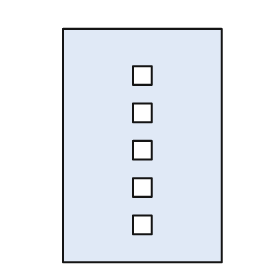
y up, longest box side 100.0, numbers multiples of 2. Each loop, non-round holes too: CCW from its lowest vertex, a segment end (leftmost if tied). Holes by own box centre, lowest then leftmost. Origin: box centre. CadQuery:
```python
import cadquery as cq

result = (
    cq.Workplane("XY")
    .moveTo(-34.0, -50.0)
    .lineTo(34.0, -50.0)
    .lineTo(34.0, 50.0)
    .lineTo(-34.0, 50.0)
    .close()
    .moveTo(-4.0, -38.0)
    .lineTo(4.0, -38.0)
    .lineTo(4.0, -30.0)
    .lineTo(-4.0, -30.0)
    .close()
    .moveTo(-4.0, -22.0)
    .lineTo(4.0, -22.0)
    .lineTo(4.0, -14.0)
    .lineTo(-4.0, -14.0)
    .close()
    .moveTo(-4.0, -6.0)
    .lineTo(4.0, -6.0)
    .lineTo(4.0, 2.0)
    .lineTo(-4.0, 2.0)
    .close()
    .moveTo(-4.0, 10.0)
    .lineTo(4.0, 10.0)
    .lineTo(4.0, 18.0)
    .lineTo(-4.0, 18.0)
    .close()
    .moveTo(-4.0, 26.0)
    .lineTo(4.0, 26.0)
    .lineTo(4.0, 34.0)
    .lineTo(-4.0, 34.0)
    .close()
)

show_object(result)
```